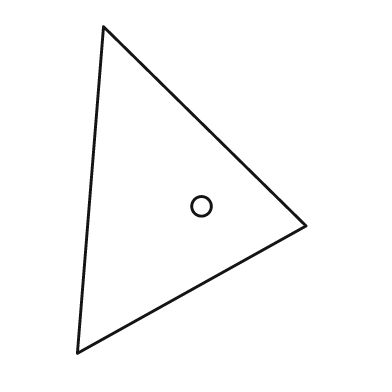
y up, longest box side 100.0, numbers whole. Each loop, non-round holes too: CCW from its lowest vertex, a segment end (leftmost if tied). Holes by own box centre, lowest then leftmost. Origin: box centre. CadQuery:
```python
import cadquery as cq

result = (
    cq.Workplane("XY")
    .moveTo(-35.0, -50.0)
    .lineTo(35.0, -11.0)
    .lineTo(-27.0, 50.0)
    .close()
    .moveTo(3.0, -5.0)
    .circle(3.0)
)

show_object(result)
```